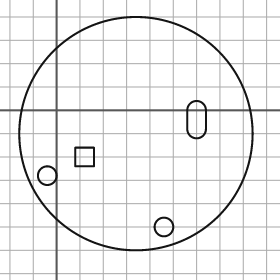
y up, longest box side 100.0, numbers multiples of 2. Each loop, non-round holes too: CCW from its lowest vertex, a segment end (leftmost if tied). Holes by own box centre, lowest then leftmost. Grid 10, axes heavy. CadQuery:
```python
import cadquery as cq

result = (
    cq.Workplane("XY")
    .moveTo(34.0, -10.0)
    .circle(50.0)
    .moveTo(46.0, -50.0)
    .circle(4.0)
    .moveTo(-4.0, -28.0)
    .circle(4.0)
    .moveTo(8.0, -24.0)
    .lineTo(16.0, -24.0)
    .lineTo(16.0, -16.0)
    .lineTo(8.0, -16.0)
    .close()
    .moveTo(56.0, -8.0)
    .threePointArc((60.0, -12.0), (64.0, -8.0))
    .lineTo(64.0, 0.0)
    .threePointArc((60.0, 4.0), (56.0, 0.0))
    .close()
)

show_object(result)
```